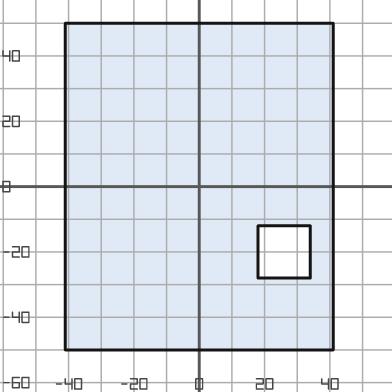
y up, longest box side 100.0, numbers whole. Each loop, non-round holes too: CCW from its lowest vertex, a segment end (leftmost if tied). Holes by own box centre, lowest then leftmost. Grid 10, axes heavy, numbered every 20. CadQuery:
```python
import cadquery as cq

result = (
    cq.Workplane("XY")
    .moveTo(-41.0, -50.0)
    .lineTo(41.0, -50.0)
    .lineTo(41.0, 50.0)
    .lineTo(-41.0, 50.0)
    .close()
    .moveTo(18.0, -28.0)
    .lineTo(34.0, -28.0)
    .lineTo(34.0, -12.0)
    .lineTo(18.0, -12.0)
    .close()
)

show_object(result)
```